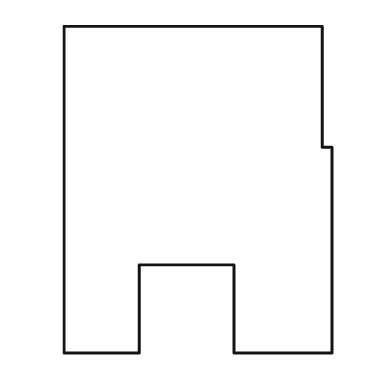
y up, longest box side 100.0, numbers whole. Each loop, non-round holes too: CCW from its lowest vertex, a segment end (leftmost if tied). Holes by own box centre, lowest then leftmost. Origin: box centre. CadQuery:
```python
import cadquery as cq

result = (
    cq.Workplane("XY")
    .moveTo(-41.0, -50.0)
    .lineTo(-18.0, -50.0)
    .lineTo(-18.0, -23.0)
    .lineTo(11.0, -23.0)
    .lineTo(11.0, -50.0)
    .lineTo(41.0, -50.0)
    .lineTo(41.0, 13.0)
    .lineTo(38.0, 13.0)
    .lineTo(38.0, 50.0)
    .lineTo(-41.0, 50.0)
    .close()
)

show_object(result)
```